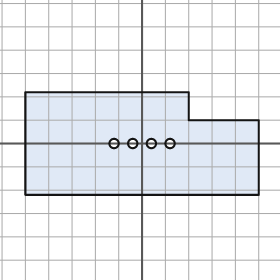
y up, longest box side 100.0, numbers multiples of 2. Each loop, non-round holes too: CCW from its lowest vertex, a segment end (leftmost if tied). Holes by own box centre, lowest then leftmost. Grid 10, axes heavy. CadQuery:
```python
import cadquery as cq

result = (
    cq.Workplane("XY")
    .moveTo(-50.0, -22.0)
    .lineTo(50.0, -22.0)
    .lineTo(50.0, 10.0)
    .lineTo(20.0, 10.0)
    .lineTo(20.0, 22.0)
    .lineTo(-50.0, 22.0)
    .close()
    .moveTo(-12.0, 0.0)
    .circle(2.0)
    .moveTo(-4.0, 0.0)
    .circle(2.0)
    .moveTo(4.0, 0.0)
    .circle(2.0)
    .moveTo(12.0, 0.0)
    .circle(2.0)
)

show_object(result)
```